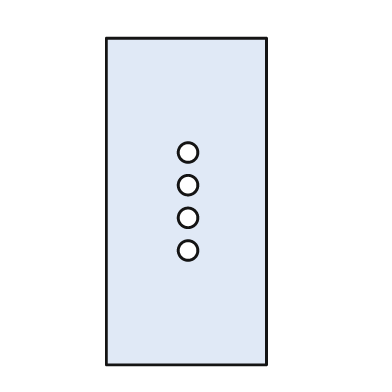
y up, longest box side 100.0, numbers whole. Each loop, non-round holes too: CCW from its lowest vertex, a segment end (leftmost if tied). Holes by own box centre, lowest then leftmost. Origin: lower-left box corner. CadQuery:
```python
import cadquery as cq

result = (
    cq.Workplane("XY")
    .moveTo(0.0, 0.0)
    .lineTo(49.0, 0.0)
    .lineTo(49.0, 100.0)
    .lineTo(0.0, 100.0)
    .close()
    .moveTo(25.0, 35.0)
    .circle(3.0)
    .moveTo(25.0, 45.0)
    .circle(3.0)
    .moveTo(25.0, 55.0)
    .circle(3.0)
    .moveTo(25.0, 65.0)
    .circle(3.0)
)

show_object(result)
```